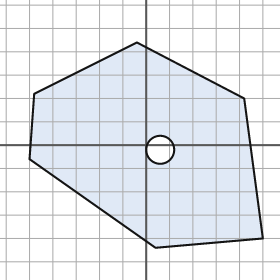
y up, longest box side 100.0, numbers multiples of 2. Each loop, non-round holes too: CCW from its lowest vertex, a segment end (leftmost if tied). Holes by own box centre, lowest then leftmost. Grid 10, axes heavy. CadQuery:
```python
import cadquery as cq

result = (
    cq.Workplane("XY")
    .moveTo(4.0, -44.0)
    .lineTo(50.0, -40.0)
    .lineTo(42.0, 20.0)
    .lineTo(-4.0, 44.0)
    .lineTo(-48.0, 22.0)
    .lineTo(-50.0, -6.0)
    .close()
    .moveTo(6.0, -2.0)
    .circle(6.0)
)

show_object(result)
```